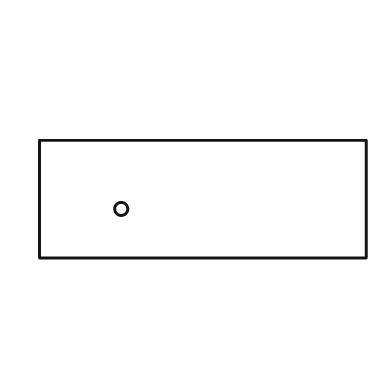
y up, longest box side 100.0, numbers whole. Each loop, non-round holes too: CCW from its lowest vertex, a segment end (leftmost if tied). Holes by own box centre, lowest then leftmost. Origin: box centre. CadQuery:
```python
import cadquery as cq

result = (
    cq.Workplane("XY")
    .moveTo(-50.0, -18.0)
    .lineTo(50.0, -18.0)
    .lineTo(50.0, 18.0)
    .lineTo(-50.0, 18.0)
    .close()
    .moveTo(-25.0, -3.0)
    .circle(2.0)
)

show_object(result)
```